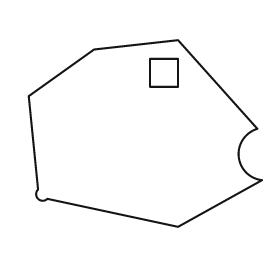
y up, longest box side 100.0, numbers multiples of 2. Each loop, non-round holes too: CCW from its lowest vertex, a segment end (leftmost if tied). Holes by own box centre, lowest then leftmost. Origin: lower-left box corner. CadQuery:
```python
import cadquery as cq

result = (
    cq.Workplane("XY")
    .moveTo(64.0, 0.0)
    .lineTo(100.0, 20.0)
    .threePointArc((90.0, 30.0), (98.0, 42.0))
    .lineTo(64.0, 80.0)
    .lineTo(28.0, 76.0)
    .lineTo(0.0, 56.0)
    .lineTo(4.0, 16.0)
    .threePointArc((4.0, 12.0), (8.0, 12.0))
    .close()
    .moveTo(52.0, 60.0)
    .lineTo(64.0, 60.0)
    .lineTo(64.0, 72.0)
    .lineTo(52.0, 72.0)
    .close()
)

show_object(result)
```